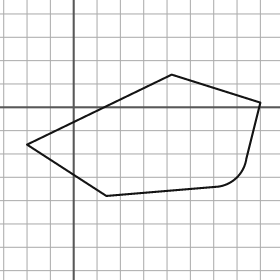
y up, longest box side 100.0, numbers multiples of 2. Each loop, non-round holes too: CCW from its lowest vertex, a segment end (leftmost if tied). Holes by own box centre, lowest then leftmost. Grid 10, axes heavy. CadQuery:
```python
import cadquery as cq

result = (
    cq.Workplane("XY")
    .moveTo(14.0, -38.0)
    .lineTo(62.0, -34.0)
    .threePointArc((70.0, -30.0), (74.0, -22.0))
    .lineTo(80.0, 2.0)
    .lineTo(42.0, 14.0)
    .lineTo(-20.0, -16.0)
    .close()
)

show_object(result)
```